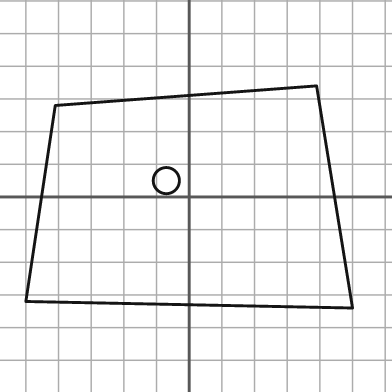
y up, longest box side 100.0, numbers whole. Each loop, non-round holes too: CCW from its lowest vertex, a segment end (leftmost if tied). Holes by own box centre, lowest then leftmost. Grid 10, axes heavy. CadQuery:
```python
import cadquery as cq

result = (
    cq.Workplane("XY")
    .moveTo(50.0, -34.0)
    .lineTo(39.0, 34.0)
    .lineTo(-41.0, 28.0)
    .lineTo(-50.0, -32.0)
    .close()
    .moveTo(-7.0, 5.0)
    .circle(4.0)
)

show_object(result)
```